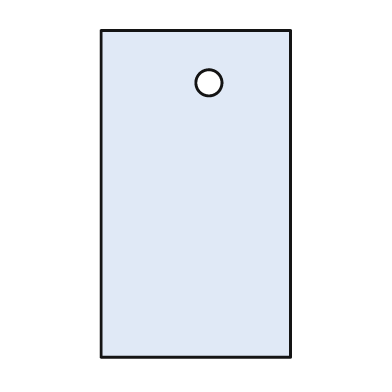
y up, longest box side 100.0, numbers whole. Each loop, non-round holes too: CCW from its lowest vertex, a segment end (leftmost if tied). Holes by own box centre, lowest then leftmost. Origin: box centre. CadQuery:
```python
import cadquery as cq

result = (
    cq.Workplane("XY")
    .moveTo(-29.0, -50.0)
    .lineTo(29.0, -50.0)
    .lineTo(29.0, 50.0)
    .lineTo(-29.0, 50.0)
    .close()
    .moveTo(4.0, 34.0)
    .circle(4.0)
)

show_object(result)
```